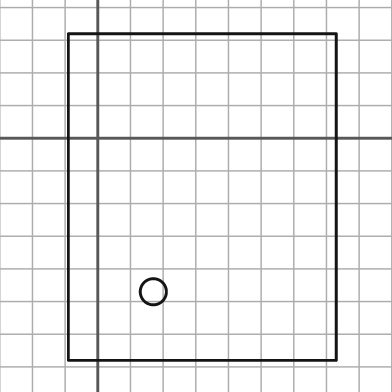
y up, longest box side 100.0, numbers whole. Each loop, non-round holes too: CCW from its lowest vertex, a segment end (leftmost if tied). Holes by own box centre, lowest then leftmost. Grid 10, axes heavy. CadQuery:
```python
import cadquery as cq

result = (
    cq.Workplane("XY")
    .moveTo(-9.0, -68.0)
    .lineTo(73.0, -68.0)
    .lineTo(73.0, 32.0)
    .lineTo(-9.0, 32.0)
    .close()
    .moveTo(17.0, -47.0)
    .circle(4.0)
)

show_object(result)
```